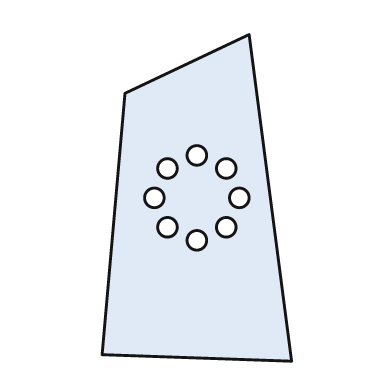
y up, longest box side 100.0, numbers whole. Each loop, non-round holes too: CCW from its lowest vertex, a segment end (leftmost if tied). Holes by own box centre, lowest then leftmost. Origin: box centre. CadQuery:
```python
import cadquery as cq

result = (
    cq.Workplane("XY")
    .moveTo(29.0, -50.0)
    .lineTo(16.0, 50.0)
    .lineTo(-22.0, 32.0)
    .lineTo(-29.0, -48.0)
    .close()
    .moveTo(0.0, -13.0)
    .circle(3.0)
    .moveTo(-9.0, -9.0)
    .circle(3.0)
    .moveTo(9.0, -9.0)
    .circle(3.0)
    .moveTo(-13.0, 0.0)
    .circle(3.0)
    .moveTo(13.0, 0.0)
    .circle(3.0)
    .moveTo(-9.0, 9.0)
    .circle(3.0)
    .moveTo(9.0, 9.0)
    .circle(3.0)
    .moveTo(0.0, 13.0)
    .circle(3.0)
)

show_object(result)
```